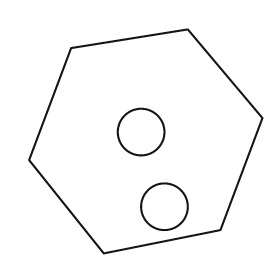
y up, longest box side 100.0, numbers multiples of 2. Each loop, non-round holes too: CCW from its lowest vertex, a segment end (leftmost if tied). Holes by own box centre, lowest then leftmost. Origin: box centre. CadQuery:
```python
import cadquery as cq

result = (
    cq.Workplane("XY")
    .moveTo(-18.0, -48.0)
    .lineTo(32.0, -38.0)
    .lineTo(50.0, 10.0)
    .lineTo(18.0, 48.0)
    .lineTo(-32.0, 40.0)
    .lineTo(-50.0, -8.0)
    .close()
    .moveTo(8.0, -28.0)
    .circle(10.0)
    .moveTo(-2.0, 4.0)
    .circle(10.0)
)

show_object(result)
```